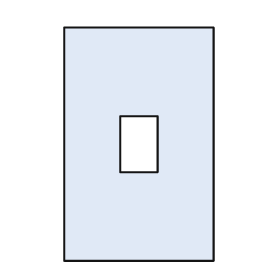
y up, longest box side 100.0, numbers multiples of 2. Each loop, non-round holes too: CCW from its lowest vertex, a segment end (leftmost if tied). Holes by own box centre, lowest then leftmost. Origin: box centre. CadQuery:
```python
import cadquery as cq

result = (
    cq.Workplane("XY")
    .moveTo(-32.0, -50.0)
    .lineTo(32.0, -50.0)
    .lineTo(32.0, 50.0)
    .lineTo(-32.0, 50.0)
    .close()
    .moveTo(-8.0, -12.0)
    .lineTo(8.0, -12.0)
    .lineTo(8.0, 12.0)
    .lineTo(-8.0, 12.0)
    .close()
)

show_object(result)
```